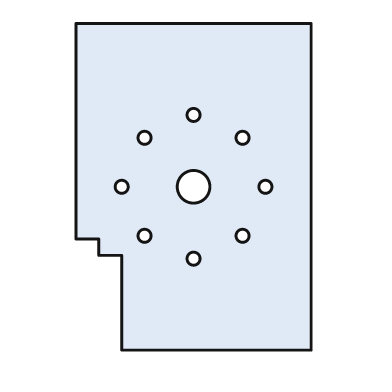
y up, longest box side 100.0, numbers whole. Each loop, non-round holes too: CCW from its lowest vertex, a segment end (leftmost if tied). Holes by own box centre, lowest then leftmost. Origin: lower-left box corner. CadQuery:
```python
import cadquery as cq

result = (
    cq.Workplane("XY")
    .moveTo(14.0, 0.0)
    .lineTo(72.0, 0.0)
    .lineTo(72.0, 100.0)
    .lineTo(0.0, 100.0)
    .lineTo(0.0, 34.0)
    .lineTo(7.0, 34.0)
    .lineTo(7.0, 29.0)
    .lineTo(14.0, 29.0)
    .close()
    .moveTo(36.0, 28.0)
    .circle(2.0)
    .moveTo(21.0, 35.0)
    .circle(2.0)
    .moveTo(51.0, 35.0)
    .circle(2.0)
    .moveTo(14.0, 50.0)
    .circle(2.0)
    .moveTo(36.0, 50.0)
    .circle(5.0)
    .moveTo(58.0, 50.0)
    .circle(2.0)
    .moveTo(21.0, 65.0)
    .circle(2.0)
    .moveTo(51.0, 65.0)
    .circle(2.0)
    .moveTo(36.0, 72.0)
    .circle(2.0)
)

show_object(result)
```